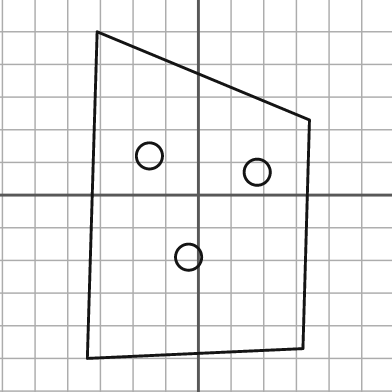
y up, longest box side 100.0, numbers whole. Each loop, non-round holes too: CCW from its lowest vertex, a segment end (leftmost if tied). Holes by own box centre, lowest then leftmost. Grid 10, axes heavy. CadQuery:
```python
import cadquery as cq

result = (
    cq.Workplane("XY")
    .moveTo(-34.0, -50.0)
    .lineTo(32.0, -47.0)
    .lineTo(34.0, 23.0)
    .lineTo(-31.0, 50.0)
    .close()
    .moveTo(-3.0, -19.0)
    .circle(4.0)
    .moveTo(18.0, 7.0)
    .circle(4.0)
    .moveTo(-15.0, 12.0)
    .circle(4.0)
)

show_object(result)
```